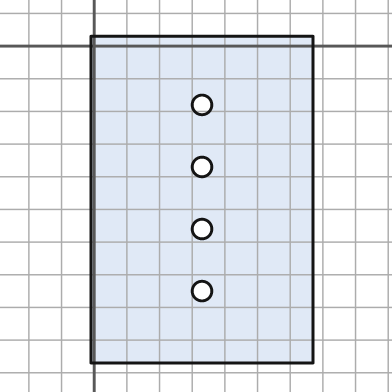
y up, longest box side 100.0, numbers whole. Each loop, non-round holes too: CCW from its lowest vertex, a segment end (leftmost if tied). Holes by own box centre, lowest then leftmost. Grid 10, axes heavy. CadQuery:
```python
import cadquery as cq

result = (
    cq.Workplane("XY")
    .moveTo(-1.0, -97.0)
    .lineTo(67.0, -97.0)
    .lineTo(67.0, 3.0)
    .lineTo(-1.0, 3.0)
    .close()
    .moveTo(33.0, -75.0)
    .circle(3.0)
    .moveTo(33.0, -56.0)
    .circle(3.0)
    .moveTo(33.0, -37.0)
    .circle(3.0)
    .moveTo(33.0, -18.0)
    .circle(3.0)
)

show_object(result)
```